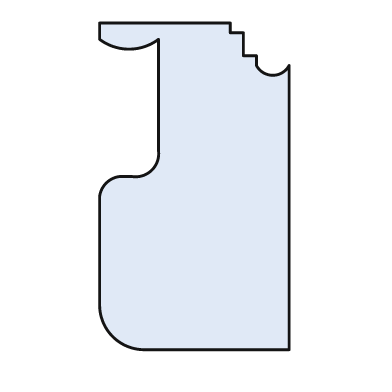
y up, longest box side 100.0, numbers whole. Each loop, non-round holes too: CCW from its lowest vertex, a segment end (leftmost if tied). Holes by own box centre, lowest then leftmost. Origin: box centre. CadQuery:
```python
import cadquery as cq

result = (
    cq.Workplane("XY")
    .moveTo(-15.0, -50.0)
    .lineTo(29.0, -50.0)
    .lineTo(29.0, 37.0)
    .threePointArc((24.0, 34.0), (19.0, 37.0))
    .lineTo(19.0, 40.0)
    .lineTo(15.0, 40.0)
    .lineTo(15.0, 47.0)
    .lineTo(11.0, 47.0)
    .lineTo(11.0, 50.0)
    .lineTo(-29.0, 50.0)
    .lineTo(-29.0, 45.0)
    .threePointArc((-20.0, 42.0), (-11.0, 45.0))
    .lineTo(-11.0, 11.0)
    .threePointArc((-13.0, 5.0), (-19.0, 3.0))
    .lineTo(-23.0, 3.0)
    .threePointArc((-27.0, 1.0), (-29.0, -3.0))
    .lineTo(-29.0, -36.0)
    .threePointArc((-25.0, -46.0), (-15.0, -50.0))
    .close()
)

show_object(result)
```